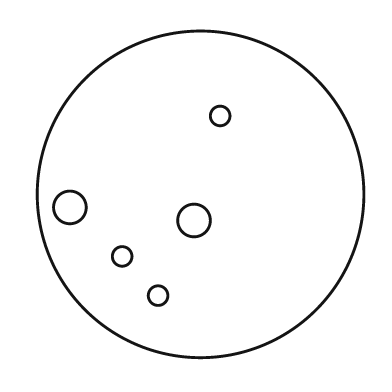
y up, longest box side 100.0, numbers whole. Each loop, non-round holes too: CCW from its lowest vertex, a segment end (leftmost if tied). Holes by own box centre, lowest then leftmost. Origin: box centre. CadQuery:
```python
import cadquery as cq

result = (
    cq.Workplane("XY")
    .moveTo(0.0, 0.0)
    .circle(50.0)
    .moveTo(-13.0, -31.0)
    .circle(3.0)
    .moveTo(-24.0, -19.0)
    .circle(3.0)
    .moveTo(-2.0, -8.0)
    .circle(5.0)
    .moveTo(-40.0, -4.0)
    .circle(5.0)
    .moveTo(6.0, 24.0)
    .circle(3.0)
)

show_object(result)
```